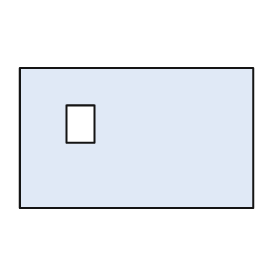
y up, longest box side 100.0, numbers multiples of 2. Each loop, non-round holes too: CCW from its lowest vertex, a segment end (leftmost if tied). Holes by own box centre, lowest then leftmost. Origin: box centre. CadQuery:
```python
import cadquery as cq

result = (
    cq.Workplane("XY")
    .moveTo(-50.0, -30.0)
    .lineTo(50.0, -30.0)
    .lineTo(50.0, 30.0)
    .lineTo(-50.0, 30.0)
    .close()
    .moveTo(-30.0, -2.0)
    .lineTo(-18.0, -2.0)
    .lineTo(-18.0, 14.0)
    .lineTo(-30.0, 14.0)
    .close()
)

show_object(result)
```